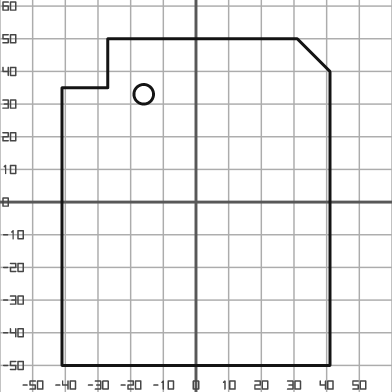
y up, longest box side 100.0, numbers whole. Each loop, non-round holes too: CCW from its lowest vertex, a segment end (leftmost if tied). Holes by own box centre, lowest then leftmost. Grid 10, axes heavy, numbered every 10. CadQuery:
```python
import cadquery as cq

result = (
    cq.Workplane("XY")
    .moveTo(-41.0, -50.0)
    .lineTo(41.0, -50.0)
    .lineTo(41.0, 40.0)
    .lineTo(31.0, 50.0)
    .lineTo(-27.0, 50.0)
    .lineTo(-27.0, 35.0)
    .lineTo(-41.0, 35.0)
    .close()
    .moveTo(-16.0, 33.0)
    .circle(3.0)
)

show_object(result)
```